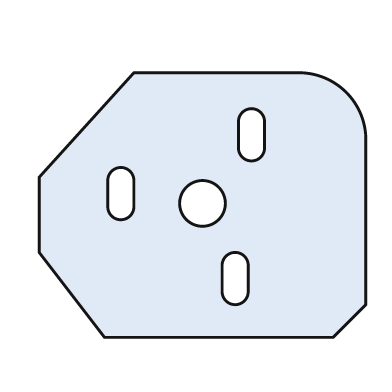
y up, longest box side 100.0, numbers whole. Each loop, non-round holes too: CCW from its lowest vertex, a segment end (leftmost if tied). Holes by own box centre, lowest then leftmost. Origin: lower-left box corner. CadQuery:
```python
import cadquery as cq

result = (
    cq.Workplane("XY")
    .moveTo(20.0, 0.0)
    .lineTo(90.0, 0.0)
    .lineTo(100.0, 10.0)
    .lineTo(100.0, 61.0)
    .threePointArc((94.0, 75.0), (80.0, 81.0))
    .lineTo(29.0, 81.0)
    .lineTo(0.0, 49.0)
    .lineTo(0.0, 26.0)
    .close()
    .moveTo(56.0, 14.0)
    .threePointArc((60.0, 10.0), (64.0, 14.0))
    .lineTo(64.0, 22.0)
    .threePointArc((60.0, 26.0), (56.0, 22.0))
    .close()
    .moveTo(50.0, 41.0)
    .circle(7.0)
    .moveTo(21.0, 40.0)
    .threePointArc((25.0, 36.0), (29.0, 40.0))
    .lineTo(29.0, 48.0)
    .threePointArc((25.0, 52.0), (21.0, 48.0))
    .close()
    .moveTo(61.0, 58.0)
    .threePointArc((65.0, 54.0), (69.0, 58.0))
    .lineTo(69.0, 66.0)
    .threePointArc((65.0, 70.0), (61.0, 66.0))
    .close()
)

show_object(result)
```